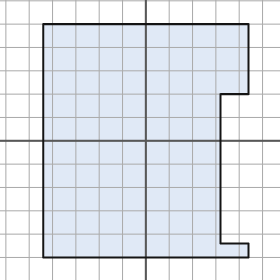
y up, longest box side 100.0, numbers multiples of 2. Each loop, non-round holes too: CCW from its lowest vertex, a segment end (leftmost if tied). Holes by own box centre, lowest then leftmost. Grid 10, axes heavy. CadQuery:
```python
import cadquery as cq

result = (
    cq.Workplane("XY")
    .moveTo(-44.0, -50.0)
    .lineTo(44.0, -50.0)
    .lineTo(44.0, -44.0)
    .lineTo(32.0, -44.0)
    .lineTo(32.0, 20.0)
    .lineTo(44.0, 20.0)
    .lineTo(44.0, 50.0)
    .lineTo(-44.0, 50.0)
    .close()
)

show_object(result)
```